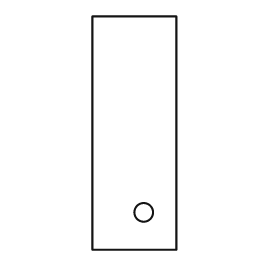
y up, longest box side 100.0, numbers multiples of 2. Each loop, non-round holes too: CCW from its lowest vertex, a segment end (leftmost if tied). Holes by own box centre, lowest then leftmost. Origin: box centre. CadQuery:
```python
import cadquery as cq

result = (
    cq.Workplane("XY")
    .moveTo(-18.0, -50.0)
    .lineTo(18.0, -50.0)
    .lineTo(18.0, 50.0)
    .lineTo(-18.0, 50.0)
    .close()
    .moveTo(4.0, -34.0)
    .circle(4.0)
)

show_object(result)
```